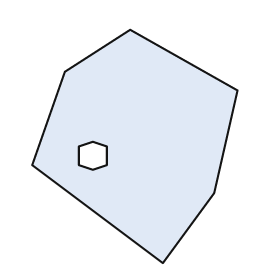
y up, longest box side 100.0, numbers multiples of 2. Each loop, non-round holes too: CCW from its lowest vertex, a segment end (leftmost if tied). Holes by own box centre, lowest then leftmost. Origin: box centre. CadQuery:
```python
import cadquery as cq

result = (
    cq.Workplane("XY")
    .moveTo(12.0, -50.0)
    .lineTo(34.0, -20.0)
    .lineTo(44.0, 24.0)
    .lineTo(-2.0, 50.0)
    .lineTo(-30.0, 32.0)
    .lineTo(-44.0, -8.0)
    .close()
    .moveTo(-18.0, -10.0)
    .lineTo(-12.0, -8.0)
    .lineTo(-12.0, 0.0)
    .lineTo(-18.0, 2.0)
    .lineTo(-24.0, 0.0)
    .lineTo(-24.0, -8.0)
    .close()
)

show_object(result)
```